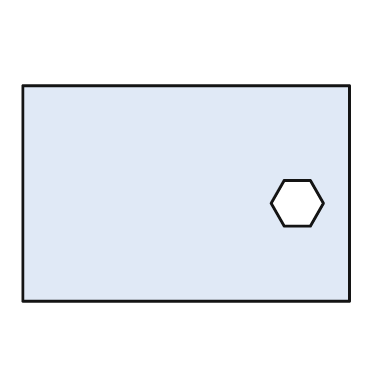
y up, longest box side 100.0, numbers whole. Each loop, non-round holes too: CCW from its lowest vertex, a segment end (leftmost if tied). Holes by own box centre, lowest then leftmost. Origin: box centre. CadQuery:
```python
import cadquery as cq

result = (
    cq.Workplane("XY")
    .moveTo(-50.0, -33.0)
    .lineTo(50.0, -33.0)
    .lineTo(50.0, 33.0)
    .lineTo(-50.0, 33.0)
    .close()
    .moveTo(30.0, -10.0)
    .lineTo(38.0, -10.0)
    .lineTo(42.0, -3.0)
    .lineTo(38.0, 4.0)
    .lineTo(30.0, 4.0)
    .lineTo(26.0, -3.0)
    .close()
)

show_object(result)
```